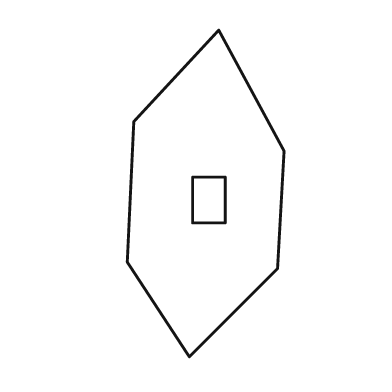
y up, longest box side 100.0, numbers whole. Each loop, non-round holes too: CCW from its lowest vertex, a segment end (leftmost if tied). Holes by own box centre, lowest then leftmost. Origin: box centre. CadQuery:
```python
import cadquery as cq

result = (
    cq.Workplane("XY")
    .moveTo(-5.0, -50.0)
    .lineTo(22.0, -23.0)
    .lineTo(24.0, 13.0)
    .lineTo(4.0, 50.0)
    .lineTo(-22.0, 22.0)
    .lineTo(-24.0, -21.0)
    .close()
    .moveTo(-4.0, -9.0)
    .lineTo(6.0, -9.0)
    .lineTo(6.0, 5.0)
    .lineTo(-4.0, 5.0)
    .close()
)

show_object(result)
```